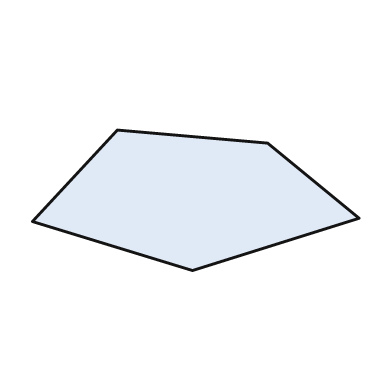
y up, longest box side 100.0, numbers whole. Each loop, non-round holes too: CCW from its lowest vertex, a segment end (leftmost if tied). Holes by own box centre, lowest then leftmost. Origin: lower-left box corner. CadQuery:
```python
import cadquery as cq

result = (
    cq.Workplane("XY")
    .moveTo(49.0, 0.0)
    .lineTo(100.0, 16.0)
    .lineTo(72.0, 39.0)
    .lineTo(26.0, 43.0)
    .lineTo(0.0, 15.0)
    .close()
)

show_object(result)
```